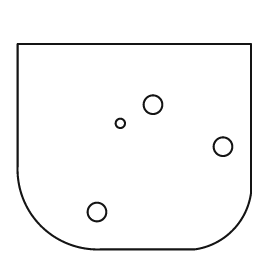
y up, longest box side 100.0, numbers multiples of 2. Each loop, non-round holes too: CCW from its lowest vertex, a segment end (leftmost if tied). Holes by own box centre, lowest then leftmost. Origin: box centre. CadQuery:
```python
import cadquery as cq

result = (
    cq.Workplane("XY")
    .moveTo(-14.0, -44.0)
    .lineTo(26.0, -44.0)
    .threePointArc((42.0, -36.0), (50.0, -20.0))
    .lineTo(50.0, 44.0)
    .lineTo(-50.0, 44.0)
    .lineTo(-50.0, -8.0)
    .threePointArc((-40.0, -34.0), (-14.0, -44.0))
    .close()
    .moveTo(-16.0, -28.0)
    .circle(4.0)
    .moveTo(38.0, 0.0)
    .circle(4.0)
    .moveTo(-6.0, 10.0)
    .circle(2.0)
    .moveTo(8.0, 18.0)
    .circle(4.0)
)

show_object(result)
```